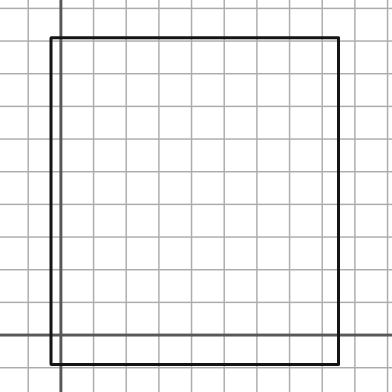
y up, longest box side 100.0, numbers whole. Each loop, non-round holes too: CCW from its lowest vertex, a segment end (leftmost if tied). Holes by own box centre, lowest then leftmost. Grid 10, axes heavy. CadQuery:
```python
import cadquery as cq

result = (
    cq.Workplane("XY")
    .moveTo(-3.0, -9.0)
    .lineTo(85.0, -9.0)
    .lineTo(85.0, 91.0)
    .lineTo(-3.0, 91.0)
    .close()
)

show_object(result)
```